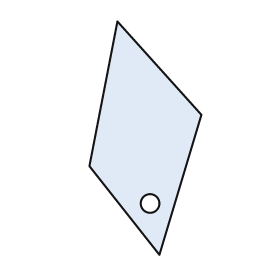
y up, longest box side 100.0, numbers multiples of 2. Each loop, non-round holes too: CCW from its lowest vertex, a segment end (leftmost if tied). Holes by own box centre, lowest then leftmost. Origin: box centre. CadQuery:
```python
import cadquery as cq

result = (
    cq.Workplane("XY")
    .moveTo(6.0, -50.0)
    .lineTo(24.0, 10.0)
    .lineTo(-12.0, 50.0)
    .lineTo(-24.0, -12.0)
    .close()
    .moveTo(2.0, -28.0)
    .circle(4.0)
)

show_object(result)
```